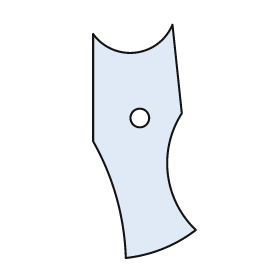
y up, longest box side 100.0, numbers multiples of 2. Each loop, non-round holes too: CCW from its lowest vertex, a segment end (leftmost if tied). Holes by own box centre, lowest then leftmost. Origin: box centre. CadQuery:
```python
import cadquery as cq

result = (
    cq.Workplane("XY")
    .moveTo(-8.0, -50.0)
    .threePointArc((8.0, -46.0), (22.0, -38.0))
    .threePointArc((10.0, -14.0), (16.0, 12.0))
    .lineTo(12.0, 50.0)
    .threePointArc((-4.0, 38.0), (-22.0, 46.0))
    .lineTo(-22.0, 0.0)
    .threePointArc((-12.0, -24.0), (-8.0, -50.0))
    .close()
    .moveTo(-2.0, 10.0)
    .circle(4.0)
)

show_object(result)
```